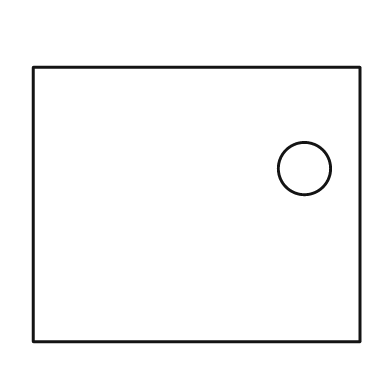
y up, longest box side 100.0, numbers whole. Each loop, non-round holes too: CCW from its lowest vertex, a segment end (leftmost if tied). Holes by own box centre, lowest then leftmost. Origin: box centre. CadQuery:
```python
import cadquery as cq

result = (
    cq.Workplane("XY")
    .moveTo(-50.0, -42.0)
    .lineTo(50.0, -42.0)
    .lineTo(50.0, 42.0)
    .lineTo(-50.0, 42.0)
    .close()
    .moveTo(33.0, 11.0)
    .circle(8.0)
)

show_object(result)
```